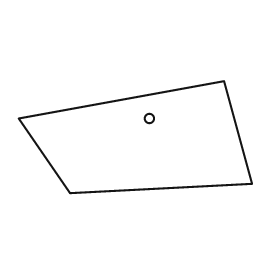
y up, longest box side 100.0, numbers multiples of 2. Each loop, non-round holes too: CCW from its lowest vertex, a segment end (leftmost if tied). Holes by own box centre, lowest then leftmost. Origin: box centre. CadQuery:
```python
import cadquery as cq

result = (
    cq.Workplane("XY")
    .moveTo(-28.0, -24.0)
    .lineTo(50.0, -20.0)
    .lineTo(38.0, 24.0)
    .lineTo(-50.0, 8.0)
    .close()
    .moveTo(6.0, 8.0)
    .circle(2.0)
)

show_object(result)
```